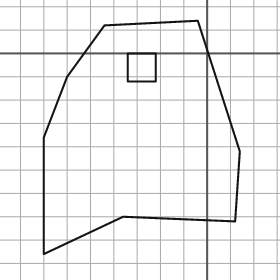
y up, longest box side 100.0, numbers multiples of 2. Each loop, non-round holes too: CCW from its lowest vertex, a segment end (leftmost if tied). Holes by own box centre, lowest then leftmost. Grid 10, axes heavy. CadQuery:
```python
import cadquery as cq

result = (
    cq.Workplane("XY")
    .moveTo(-70.0, -86.0)
    .lineTo(-36.0, -70.0)
    .lineTo(12.0, -72.0)
    .lineTo(14.0, -42.0)
    .lineTo(-4.0, 14.0)
    .lineTo(-44.0, 12.0)
    .lineTo(-60.0, -10.0)
    .lineTo(-70.0, -36.0)
    .close()
    .moveTo(-34.0, -12.0)
    .lineTo(-22.0, -12.0)
    .lineTo(-22.0, 0.0)
    .lineTo(-34.0, 0.0)
    .close()
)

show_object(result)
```